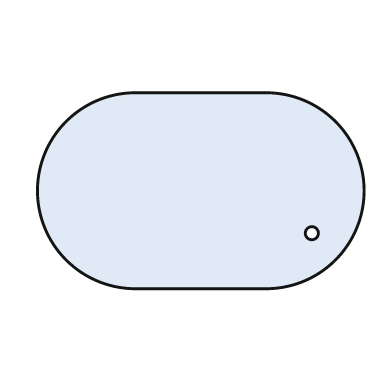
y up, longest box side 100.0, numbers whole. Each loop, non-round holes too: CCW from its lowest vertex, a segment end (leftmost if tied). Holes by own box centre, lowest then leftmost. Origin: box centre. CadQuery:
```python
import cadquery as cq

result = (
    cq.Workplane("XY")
    .moveTo(-20.0, -30.0)
    .lineTo(20.0, -30.0)
    .threePointArc((50.0, 0.0), (20.0, 30.0))
    .lineTo(-20.0, 30.0)
    .threePointArc((-50.0, 0.0), (-20.0, -30.0))
    .close()
    .moveTo(34.0, -13.0)
    .circle(2.0)
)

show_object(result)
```